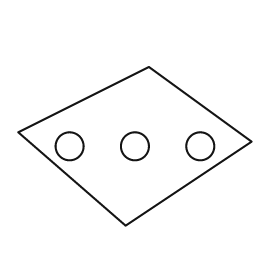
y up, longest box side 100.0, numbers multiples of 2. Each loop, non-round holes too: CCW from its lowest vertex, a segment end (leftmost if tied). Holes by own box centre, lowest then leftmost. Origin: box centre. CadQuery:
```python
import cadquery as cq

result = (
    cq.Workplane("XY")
    .moveTo(-4.0, -34.0)
    .lineTo(50.0, 2.0)
    .lineTo(6.0, 34.0)
    .lineTo(-50.0, 6.0)
    .close()
    .moveTo(-28.0, 0.0)
    .circle(6.0)
    .moveTo(0.0, 0.0)
    .circle(6.0)
    .moveTo(28.0, 0.0)
    .circle(6.0)
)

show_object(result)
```